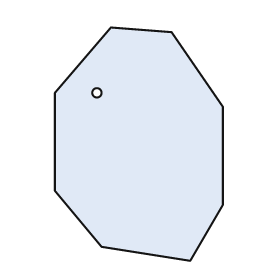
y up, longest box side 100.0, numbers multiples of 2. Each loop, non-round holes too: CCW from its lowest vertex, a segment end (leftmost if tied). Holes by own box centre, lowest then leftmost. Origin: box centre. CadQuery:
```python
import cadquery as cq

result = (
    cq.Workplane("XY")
    .moveTo(22.0, -50.0)
    .lineTo(36.0, -26.0)
    .lineTo(36.0, 16.0)
    .lineTo(14.0, 48.0)
    .lineTo(-12.0, 50.0)
    .lineTo(-36.0, 22.0)
    .lineTo(-36.0, -20.0)
    .lineTo(-16.0, -44.0)
    .close()
    .moveTo(-18.0, 22.0)
    .circle(2.0)
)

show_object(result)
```